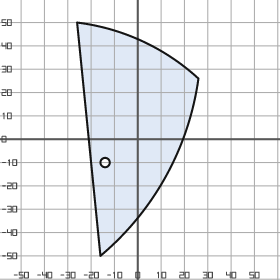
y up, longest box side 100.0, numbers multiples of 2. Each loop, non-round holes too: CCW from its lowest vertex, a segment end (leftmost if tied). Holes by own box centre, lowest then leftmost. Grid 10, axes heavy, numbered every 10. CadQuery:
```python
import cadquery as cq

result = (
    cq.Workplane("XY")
    .moveTo(-16.0, -50.0)
    .threePointArc((12.0, -16.0), (26.0, 26.0))
    .threePointArc((2.0, 42.0), (-26.0, 50.0))
    .close()
    .moveTo(-14.0, -10.0)
    .circle(2.0)
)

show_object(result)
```